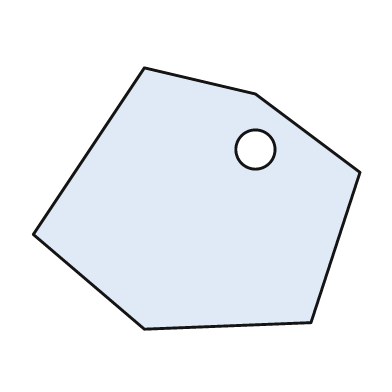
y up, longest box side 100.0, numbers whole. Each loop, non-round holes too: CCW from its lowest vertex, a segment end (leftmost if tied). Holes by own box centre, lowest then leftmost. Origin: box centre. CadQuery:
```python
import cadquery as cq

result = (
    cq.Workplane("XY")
    .moveTo(-16.0, -40.0)
    .lineTo(35.0, -38.0)
    .lineTo(50.0, 8.0)
    .lineTo(18.0, 32.0)
    .lineTo(-16.0, 40.0)
    .lineTo(-50.0, -11.0)
    .close()
    .moveTo(18.0, 15.0)
    .circle(6.0)
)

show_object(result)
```